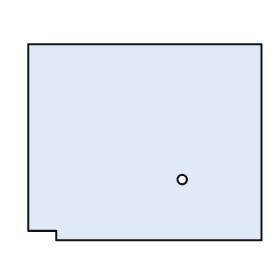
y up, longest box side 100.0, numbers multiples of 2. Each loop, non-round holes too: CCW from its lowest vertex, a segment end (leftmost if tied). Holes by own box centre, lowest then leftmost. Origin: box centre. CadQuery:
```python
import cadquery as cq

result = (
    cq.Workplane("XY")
    .moveTo(-38.0, -42.0)
    .lineTo(50.0, -42.0)
    .lineTo(50.0, 42.0)
    .lineTo(-50.0, 42.0)
    .lineTo(-50.0, -38.0)
    .lineTo(-38.0, -38.0)
    .close()
    .moveTo(16.0, -16.0)
    .circle(2.0)
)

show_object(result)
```